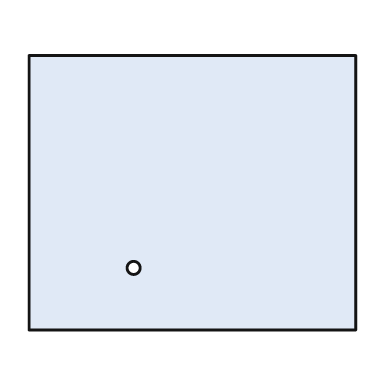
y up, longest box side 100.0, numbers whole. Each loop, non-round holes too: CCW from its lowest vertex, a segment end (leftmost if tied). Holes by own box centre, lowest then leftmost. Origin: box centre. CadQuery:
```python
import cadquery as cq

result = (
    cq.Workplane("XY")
    .moveTo(-50.0, -42.0)
    .lineTo(50.0, -42.0)
    .lineTo(50.0, 42.0)
    .lineTo(-50.0, 42.0)
    .close()
    .moveTo(-18.0, -23.0)
    .circle(2.0)
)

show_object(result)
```